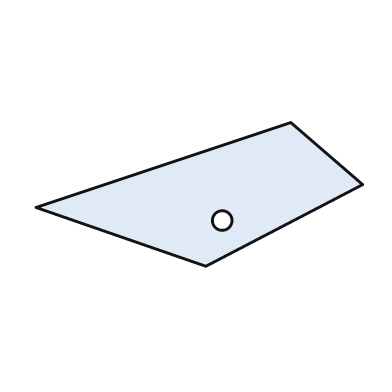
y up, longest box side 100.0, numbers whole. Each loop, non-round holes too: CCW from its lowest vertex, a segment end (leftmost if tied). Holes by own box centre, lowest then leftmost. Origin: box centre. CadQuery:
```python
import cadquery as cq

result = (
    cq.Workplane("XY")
    .moveTo(2.0, -22.0)
    .lineTo(50.0, 3.0)
    .lineTo(28.0, 22.0)
    .lineTo(-50.0, -4.0)
    .close()
    .moveTo(7.0, -8.0)
    .circle(3.0)
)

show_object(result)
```